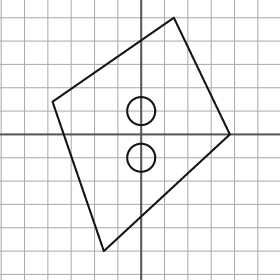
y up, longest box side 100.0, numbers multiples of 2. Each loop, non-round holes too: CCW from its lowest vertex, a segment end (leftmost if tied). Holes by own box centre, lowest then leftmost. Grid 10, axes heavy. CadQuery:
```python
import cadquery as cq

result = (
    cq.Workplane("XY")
    .moveTo(-16.0, -50.0)
    .lineTo(38.0, 0.0)
    .lineTo(14.0, 50.0)
    .lineTo(-38.0, 14.0)
    .close()
    .moveTo(0.0, -10.0)
    .circle(6.0)
    .moveTo(0.0, 10.0)
    .circle(6.0)
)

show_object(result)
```